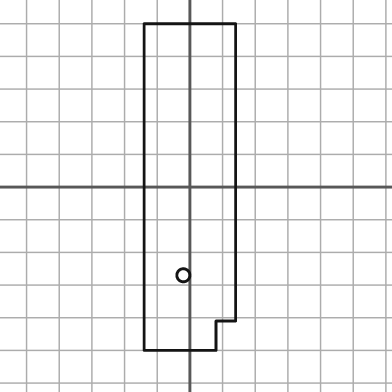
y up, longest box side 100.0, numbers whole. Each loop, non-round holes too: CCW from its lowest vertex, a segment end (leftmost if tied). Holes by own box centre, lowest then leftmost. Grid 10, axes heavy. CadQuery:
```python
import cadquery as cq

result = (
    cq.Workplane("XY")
    .moveTo(-14.0, -50.0)
    .lineTo(8.0, -50.0)
    .lineTo(8.0, -41.0)
    .lineTo(14.0, -41.0)
    .lineTo(14.0, 50.0)
    .lineTo(-14.0, 50.0)
    .close()
    .moveTo(-2.0, -27.0)
    .circle(2.0)
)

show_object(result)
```